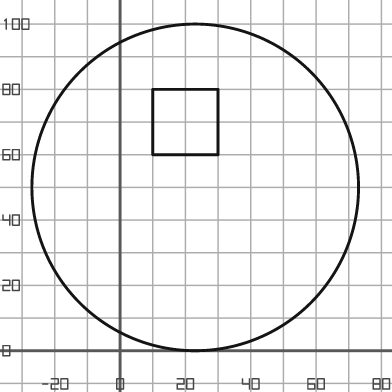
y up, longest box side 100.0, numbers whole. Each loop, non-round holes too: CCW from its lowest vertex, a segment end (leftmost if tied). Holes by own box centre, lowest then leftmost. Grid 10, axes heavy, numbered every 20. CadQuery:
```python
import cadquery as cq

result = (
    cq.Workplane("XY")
    .moveTo(23.0, 50.0)
    .circle(50.0)
    .moveTo(10.0, 60.0)
    .lineTo(30.0, 60.0)
    .lineTo(30.0, 80.0)
    .lineTo(10.0, 80.0)
    .close()
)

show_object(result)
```